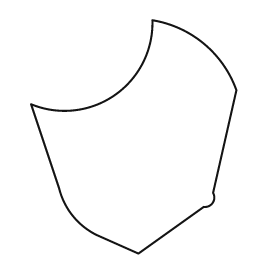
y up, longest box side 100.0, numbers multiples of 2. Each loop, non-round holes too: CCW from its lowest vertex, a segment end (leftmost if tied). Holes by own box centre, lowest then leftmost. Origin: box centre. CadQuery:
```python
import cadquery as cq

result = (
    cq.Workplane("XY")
    .moveTo(2.0, -50.0)
    .lineTo(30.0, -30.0)
    .threePointArc((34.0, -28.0), (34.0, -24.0))
    .lineTo(44.0, 20.0)
    .threePointArc((30.0, 40.0), (8.0, 50.0))
    .threePointArc((-8.0, 18.0), (-44.0, 14.0))
    .lineTo(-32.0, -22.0)
    .threePointArc((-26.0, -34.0), (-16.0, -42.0))
    .close()
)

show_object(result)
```